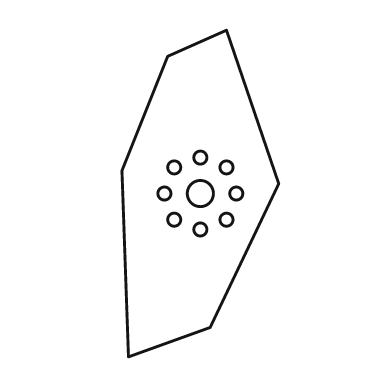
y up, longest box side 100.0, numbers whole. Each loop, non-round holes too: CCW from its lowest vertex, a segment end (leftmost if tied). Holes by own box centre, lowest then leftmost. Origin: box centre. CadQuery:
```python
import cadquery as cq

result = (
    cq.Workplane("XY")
    .moveTo(-22.0, -50.0)
    .lineTo(3.0, -41.0)
    .lineTo(24.0, 3.0)
    .lineTo(8.0, 50.0)
    .lineTo(-10.0, 42.0)
    .lineTo(-24.0, 7.0)
    .close()
    .moveTo(0.0, -11.0)
    .circle(2.0)
    .moveTo(-8.0, -8.0)
    .circle(2.0)
    .moveTo(8.0, -8.0)
    .circle(2.0)
    .moveTo(-11.0, 0.0)
    .circle(2.0)
    .moveTo(0.0, 0.0)
    .circle(4.0)
    .moveTo(11.0, 0.0)
    .circle(2.0)
    .moveTo(-8.0, 8.0)
    .circle(2.0)
    .moveTo(8.0, 8.0)
    .circle(2.0)
    .moveTo(0.0, 11.0)
    .circle(2.0)
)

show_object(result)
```